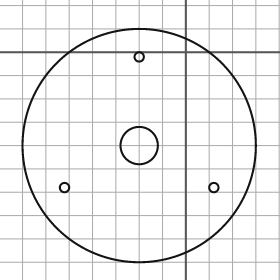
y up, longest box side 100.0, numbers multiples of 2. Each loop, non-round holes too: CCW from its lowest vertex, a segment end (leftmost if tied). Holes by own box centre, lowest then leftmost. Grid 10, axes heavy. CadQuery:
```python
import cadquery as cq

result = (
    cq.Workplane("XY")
    .moveTo(-20.0, -40.0)
    .circle(50.0)
    .moveTo(-52.0, -58.0)
    .circle(2.0)
    .moveTo(12.0, -58.0)
    .circle(2.0)
    .moveTo(-20.0, -40.0)
    .circle(8.0)
    .moveTo(-20.0, -2.0)
    .circle(2.0)
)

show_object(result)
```